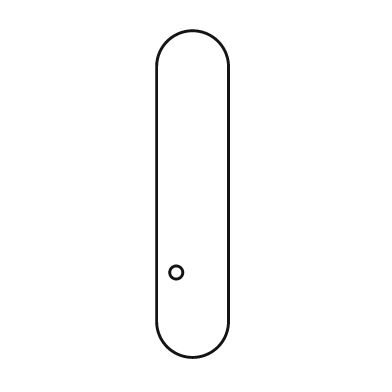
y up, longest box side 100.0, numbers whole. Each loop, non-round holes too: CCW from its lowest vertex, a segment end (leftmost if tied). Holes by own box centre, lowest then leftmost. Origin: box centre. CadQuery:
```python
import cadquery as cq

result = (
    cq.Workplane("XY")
    .moveTo(-11.0, -39.0)
    .threePointArc((0.0, -50.0), (11.0, -39.0))
    .lineTo(11.0, 39.0)
    .threePointArc((0.0, 50.0), (-11.0, 39.0))
    .close()
    .moveTo(-5.0, -24.0)
    .circle(2.0)
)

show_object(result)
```